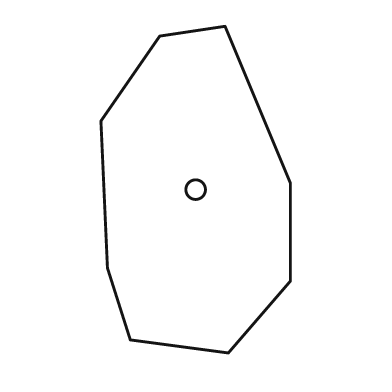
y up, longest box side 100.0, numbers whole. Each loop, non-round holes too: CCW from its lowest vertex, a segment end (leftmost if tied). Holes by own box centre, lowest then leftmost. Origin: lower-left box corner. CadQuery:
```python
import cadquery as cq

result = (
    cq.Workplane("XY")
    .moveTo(39.0, 0.0)
    .lineTo(58.0, 22.0)
    .lineTo(58.0, 52.0)
    .lineTo(38.0, 100.0)
    .lineTo(18.0, 97.0)
    .lineTo(0.0, 71.0)
    .lineTo(2.0, 26.0)
    .lineTo(9.0, 4.0)
    .close()
    .moveTo(29.0, 50.0)
    .circle(3.0)
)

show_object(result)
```